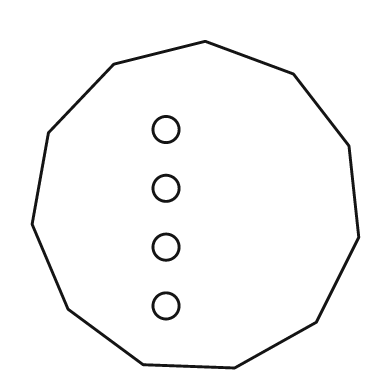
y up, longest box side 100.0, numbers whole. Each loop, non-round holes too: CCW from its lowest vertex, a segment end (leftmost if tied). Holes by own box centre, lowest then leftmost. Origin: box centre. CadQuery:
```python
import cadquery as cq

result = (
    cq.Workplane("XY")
    .moveTo(12.0, -50.0)
    .lineTo(37.0, -36.0)
    .lineTo(50.0, -10.0)
    .lineTo(47.0, 18.0)
    .lineTo(30.0, 40.0)
    .lineTo(3.0, 50.0)
    .lineTo(-25.0, 43.0)
    .lineTo(-45.0, 22.0)
    .lineTo(-50.0, -6.0)
    .lineTo(-39.0, -32.0)
    .lineTo(-16.0, -49.0)
    .close()
    .moveTo(-9.0, -31.0)
    .circle(4.0)
    .moveTo(-9.0, -13.0)
    .circle(4.0)
    .moveTo(-9.0, 5.0)
    .circle(4.0)
    .moveTo(-9.0, 23.0)
    .circle(4.0)
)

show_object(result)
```